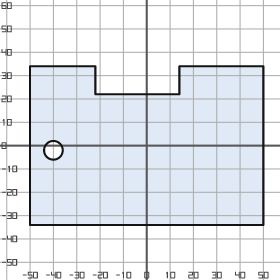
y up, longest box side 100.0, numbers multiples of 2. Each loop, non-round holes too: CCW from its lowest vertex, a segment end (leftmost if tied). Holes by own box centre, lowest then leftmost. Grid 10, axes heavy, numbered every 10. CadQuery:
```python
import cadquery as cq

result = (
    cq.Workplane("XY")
    .moveTo(-50.0, -34.0)
    .lineTo(50.0, -34.0)
    .lineTo(50.0, 34.0)
    .lineTo(14.0, 34.0)
    .lineTo(14.0, 22.0)
    .lineTo(-22.0, 22.0)
    .lineTo(-22.0, 34.0)
    .lineTo(-50.0, 34.0)
    .close()
    .moveTo(-40.0, -2.0)
    .circle(4.0)
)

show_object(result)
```